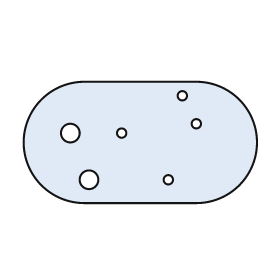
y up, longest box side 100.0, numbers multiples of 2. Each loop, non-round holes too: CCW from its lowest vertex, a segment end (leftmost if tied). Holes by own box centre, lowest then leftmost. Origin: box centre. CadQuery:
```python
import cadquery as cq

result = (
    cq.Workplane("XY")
    .moveTo(-24.0, -26.0)
    .lineTo(24.0, -26.0)
    .threePointArc((50.0, 0.0), (24.0, 26.0))
    .lineTo(-24.0, 26.0)
    .threePointArc((-50.0, 0.0), (-24.0, -26.0))
    .close()
    .moveTo(-22.0, -16.0)
    .circle(4.0)
    .moveTo(12.0, -16.0)
    .circle(2.0)
    .moveTo(-30.0, 4.0)
    .circle(4.0)
    .moveTo(-8.0, 4.0)
    .circle(2.0)
    .moveTo(24.0, 8.0)
    .circle(2.0)
    .moveTo(18.0, 20.0)
    .circle(2.0)
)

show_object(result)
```